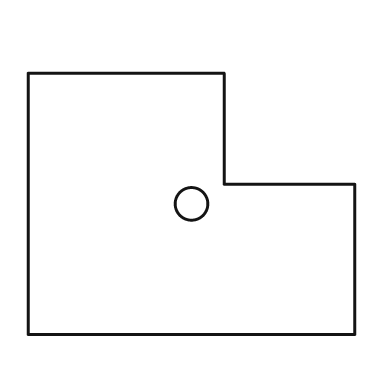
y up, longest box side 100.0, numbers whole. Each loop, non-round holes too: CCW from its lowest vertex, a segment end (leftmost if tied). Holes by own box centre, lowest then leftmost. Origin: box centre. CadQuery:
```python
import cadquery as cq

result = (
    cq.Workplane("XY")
    .moveTo(-50.0, -40.0)
    .lineTo(50.0, -40.0)
    .lineTo(50.0, 6.0)
    .lineTo(10.0, 6.0)
    .lineTo(10.0, 40.0)
    .lineTo(-50.0, 40.0)
    .close()
    .moveTo(0.0, 0.0)
    .circle(5.0)
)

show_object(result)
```